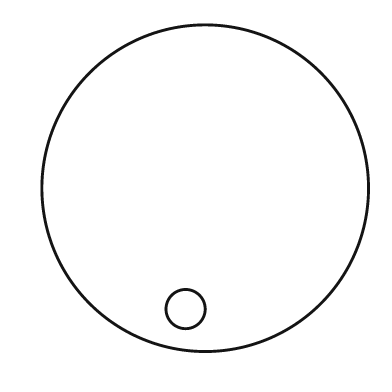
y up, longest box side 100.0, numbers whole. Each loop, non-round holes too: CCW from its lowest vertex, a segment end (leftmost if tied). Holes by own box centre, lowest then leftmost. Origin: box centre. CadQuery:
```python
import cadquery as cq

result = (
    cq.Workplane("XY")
    .moveTo(0.0, 0.0)
    .circle(50.0)
    .moveTo(-6.0, -37.0)
    .circle(6.0)
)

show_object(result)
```